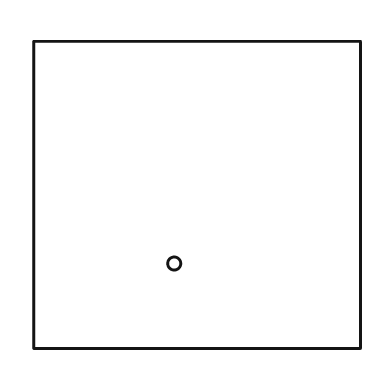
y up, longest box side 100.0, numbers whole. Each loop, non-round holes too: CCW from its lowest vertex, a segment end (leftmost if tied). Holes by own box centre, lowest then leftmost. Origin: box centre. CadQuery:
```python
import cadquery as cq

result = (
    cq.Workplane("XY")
    .moveTo(-50.0, -47.0)
    .lineTo(50.0, -47.0)
    .lineTo(50.0, 47.0)
    .lineTo(-50.0, 47.0)
    .close()
    .moveTo(-7.0, -21.0)
    .circle(2.0)
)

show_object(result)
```